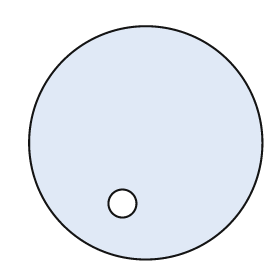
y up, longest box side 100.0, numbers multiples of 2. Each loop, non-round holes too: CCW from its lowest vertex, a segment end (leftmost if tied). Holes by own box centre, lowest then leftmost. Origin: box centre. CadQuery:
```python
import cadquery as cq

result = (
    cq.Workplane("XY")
    .moveTo(0.0, 0.0)
    .circle(50.0)
    .moveTo(-10.0, -26.0)
    .circle(6.0)
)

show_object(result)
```